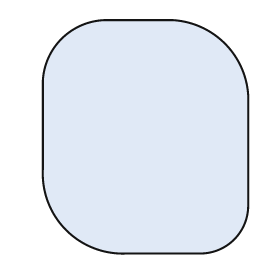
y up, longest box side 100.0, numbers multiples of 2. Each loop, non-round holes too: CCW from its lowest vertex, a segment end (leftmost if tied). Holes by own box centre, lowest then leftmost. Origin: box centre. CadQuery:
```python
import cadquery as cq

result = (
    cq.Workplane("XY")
    .moveTo(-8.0, -50.0)
    .lineTo(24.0, -50.0)
    .threePointArc((38.0, -44.0), (44.0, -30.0))
    .lineTo(44.0, 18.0)
    .threePointArc((34.0, 40.0), (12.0, 50.0))
    .lineTo(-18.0, 50.0)
    .threePointArc((-36.0, 42.0), (-44.0, 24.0))
    .lineTo(-44.0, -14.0)
    .threePointArc((-34.0, -40.0), (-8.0, -50.0))
    .close()
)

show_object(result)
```